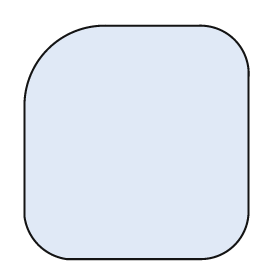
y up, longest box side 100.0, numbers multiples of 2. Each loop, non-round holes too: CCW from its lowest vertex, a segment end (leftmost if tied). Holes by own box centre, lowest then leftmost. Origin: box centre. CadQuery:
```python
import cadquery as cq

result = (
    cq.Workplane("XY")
    .moveTo(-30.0, -50.0)
    .lineTo(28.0, -50.0)
    .threePointArc((42.0, -44.0), (48.0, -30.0))
    .lineTo(48.0, 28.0)
    .threePointArc((42.0, 44.0), (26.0, 50.0))
    .lineTo(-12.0, 50.0)
    .threePointArc((-38.0, 40.0), (-48.0, 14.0))
    .lineTo(-48.0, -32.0)
    .threePointArc((-42.0, -44.0), (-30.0, -50.0))
    .close()
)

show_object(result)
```